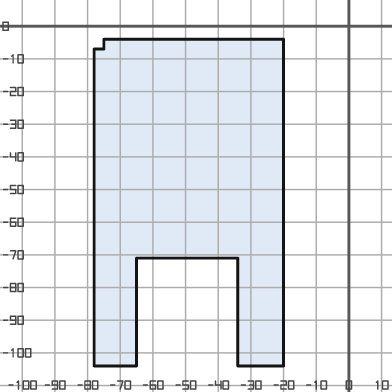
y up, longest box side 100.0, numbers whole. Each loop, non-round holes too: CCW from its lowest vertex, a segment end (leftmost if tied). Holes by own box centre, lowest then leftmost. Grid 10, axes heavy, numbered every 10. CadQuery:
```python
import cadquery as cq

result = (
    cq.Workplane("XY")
    .moveTo(-78.0, -104.0)
    .lineTo(-65.0, -104.0)
    .lineTo(-65.0, -71.0)
    .lineTo(-34.0, -71.0)
    .lineTo(-34.0, -104.0)
    .lineTo(-20.0, -104.0)
    .lineTo(-20.0, -4.0)
    .lineTo(-75.0, -4.0)
    .lineTo(-75.0, -7.0)
    .lineTo(-78.0, -7.0)
    .close()
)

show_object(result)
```